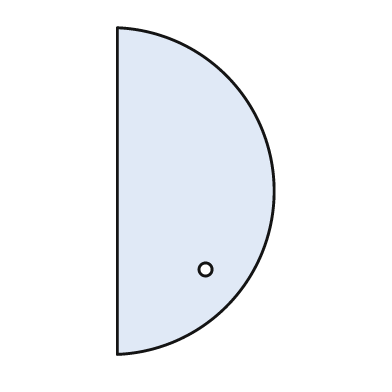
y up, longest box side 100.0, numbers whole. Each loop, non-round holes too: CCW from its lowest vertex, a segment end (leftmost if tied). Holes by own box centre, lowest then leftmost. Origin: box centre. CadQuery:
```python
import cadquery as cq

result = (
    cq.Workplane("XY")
    .moveTo(-24.0, -50.0)
    .threePointArc((24.0, 0.0), (-24.0, 50.0))
    .close()
    .moveTo(3.0, -24.0)
    .circle(2.0)
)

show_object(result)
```